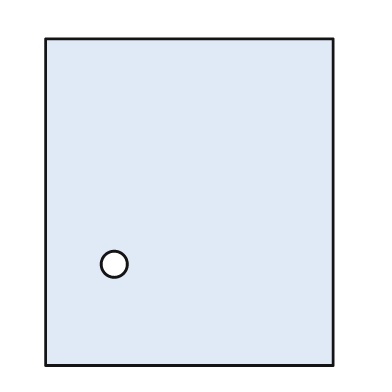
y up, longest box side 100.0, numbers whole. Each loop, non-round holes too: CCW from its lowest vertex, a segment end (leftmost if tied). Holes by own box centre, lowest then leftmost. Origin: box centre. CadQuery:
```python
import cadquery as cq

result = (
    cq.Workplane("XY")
    .moveTo(-44.0, -50.0)
    .lineTo(44.0, -50.0)
    .lineTo(44.0, 50.0)
    .lineTo(-44.0, 50.0)
    .close()
    .moveTo(-23.0, -19.0)
    .circle(4.0)
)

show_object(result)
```